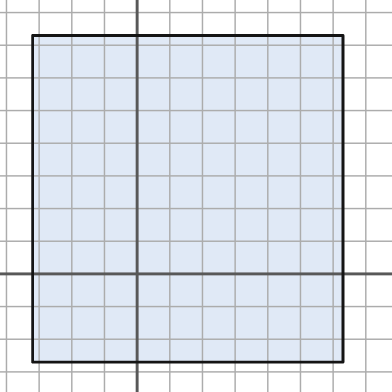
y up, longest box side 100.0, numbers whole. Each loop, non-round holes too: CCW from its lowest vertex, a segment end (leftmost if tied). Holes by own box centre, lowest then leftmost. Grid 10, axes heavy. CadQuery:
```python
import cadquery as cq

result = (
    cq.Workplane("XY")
    .moveTo(-32.0, -27.0)
    .lineTo(63.0, -27.0)
    .lineTo(63.0, 73.0)
    .lineTo(-32.0, 73.0)
    .close()
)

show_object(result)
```